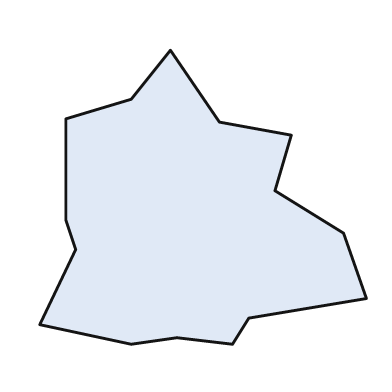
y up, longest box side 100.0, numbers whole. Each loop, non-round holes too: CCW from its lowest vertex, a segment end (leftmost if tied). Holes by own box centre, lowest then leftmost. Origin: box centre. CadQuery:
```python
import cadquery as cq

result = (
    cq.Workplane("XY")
    .moveTo(-22.0, -45.0)
    .lineTo(-8.0, -43.0)
    .lineTo(9.0, -45.0)
    .lineTo(14.0, -37.0)
    .lineTo(50.0, -31.0)
    .lineTo(43.0, -11.0)
    .lineTo(22.0, 2.0)
    .lineTo(27.0, 19.0)
    .lineTo(5.0, 23.0)
    .lineTo(-10.0, 45.0)
    .lineTo(-22.0, 30.0)
    .lineTo(-42.0, 24.0)
    .lineTo(-42.0, -7.0)
    .lineTo(-39.0, -16.0)
    .lineTo(-50.0, -39.0)
    .close()
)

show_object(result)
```